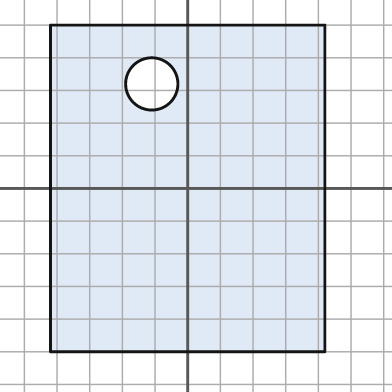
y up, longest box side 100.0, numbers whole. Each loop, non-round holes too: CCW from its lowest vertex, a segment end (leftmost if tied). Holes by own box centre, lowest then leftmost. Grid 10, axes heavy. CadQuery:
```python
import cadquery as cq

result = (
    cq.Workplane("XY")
    .moveTo(-42.0, -50.0)
    .lineTo(42.0, -50.0)
    .lineTo(42.0, 50.0)
    .lineTo(-42.0, 50.0)
    .close()
    .moveTo(-11.0, 32.0)
    .circle(8.0)
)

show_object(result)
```